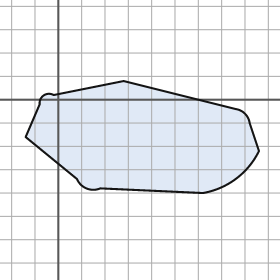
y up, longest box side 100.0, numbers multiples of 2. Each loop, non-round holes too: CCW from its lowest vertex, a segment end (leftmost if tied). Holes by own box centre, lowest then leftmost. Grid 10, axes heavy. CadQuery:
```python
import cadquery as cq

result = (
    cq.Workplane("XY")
    .moveTo(62.0, -40.0)
    .threePointArc((76.0, -34.0), (86.0, -22.0))
    .lineTo(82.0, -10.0)
    .threePointArc((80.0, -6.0), (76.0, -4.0))
    .lineTo(28.0, 8.0)
    .lineTo(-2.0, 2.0)
    .threePointArc((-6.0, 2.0), (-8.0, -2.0))
    .lineTo(-14.0, -16.0)
    .lineTo(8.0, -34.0)
    .threePointArc((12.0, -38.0), (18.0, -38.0))
    .close()
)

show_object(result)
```